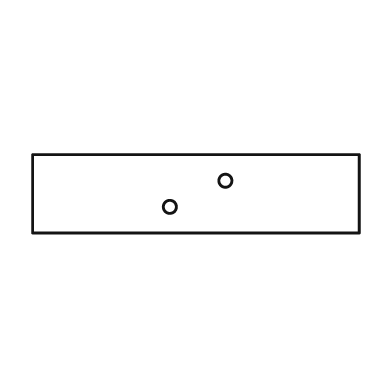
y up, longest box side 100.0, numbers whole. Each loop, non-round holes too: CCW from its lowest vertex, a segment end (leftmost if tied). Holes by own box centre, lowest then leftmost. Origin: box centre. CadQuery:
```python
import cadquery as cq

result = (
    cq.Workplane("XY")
    .moveTo(-50.0, -12.0)
    .lineTo(50.0, -12.0)
    .lineTo(50.0, 12.0)
    .lineTo(-50.0, 12.0)
    .close()
    .moveTo(-8.0, -4.0)
    .circle(2.0)
    .moveTo(9.0, 4.0)
    .circle(2.0)
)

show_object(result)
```